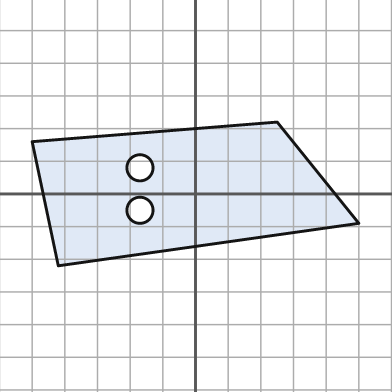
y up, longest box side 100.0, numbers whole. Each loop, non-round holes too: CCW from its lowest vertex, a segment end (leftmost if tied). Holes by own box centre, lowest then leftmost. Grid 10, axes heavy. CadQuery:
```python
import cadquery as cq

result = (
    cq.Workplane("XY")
    .moveTo(-42.0, -22.0)
    .lineTo(50.0, -9.0)
    .lineTo(25.0, 22.0)
    .lineTo(-50.0, 16.0)
    .close()
    .moveTo(-17.0, -5.0)
    .circle(4.0)
    .moveTo(-17.0, 8.0)
    .circle(4.0)
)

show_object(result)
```